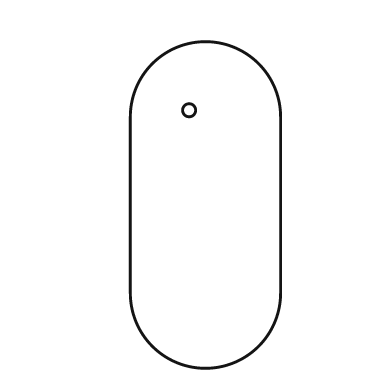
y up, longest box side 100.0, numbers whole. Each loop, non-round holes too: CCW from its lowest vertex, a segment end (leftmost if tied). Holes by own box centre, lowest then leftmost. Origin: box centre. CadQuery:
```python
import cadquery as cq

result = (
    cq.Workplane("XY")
    .moveTo(-23.0, -27.0)
    .threePointArc((0.0, -50.0), (23.0, -27.0))
    .lineTo(23.0, 27.0)
    .threePointArc((0.0, 50.0), (-23.0, 27.0))
    .close()
    .moveTo(-5.0, 29.0)
    .circle(2.0)
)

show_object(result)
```